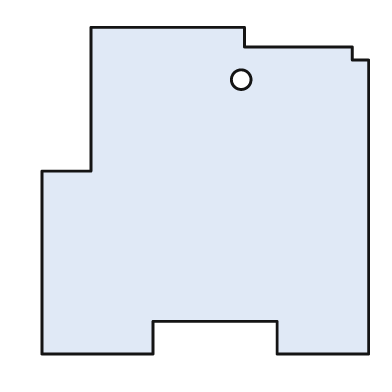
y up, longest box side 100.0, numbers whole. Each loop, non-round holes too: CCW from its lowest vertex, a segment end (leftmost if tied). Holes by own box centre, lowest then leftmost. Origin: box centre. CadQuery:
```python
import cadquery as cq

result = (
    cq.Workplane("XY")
    .moveTo(-50.0, -50.0)
    .lineTo(-16.0, -50.0)
    .lineTo(-16.0, -40.0)
    .lineTo(22.0, -40.0)
    .lineTo(22.0, -50.0)
    .lineTo(50.0, -50.0)
    .lineTo(50.0, 40.0)
    .lineTo(45.0, 40.0)
    .lineTo(45.0, 44.0)
    .lineTo(12.0, 44.0)
    .lineTo(12.0, 50.0)
    .lineTo(-35.0, 50.0)
    .lineTo(-35.0, 6.0)
    .lineTo(-50.0, 6.0)
    .close()
    .moveTo(11.0, 34.0)
    .circle(3.0)
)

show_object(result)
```